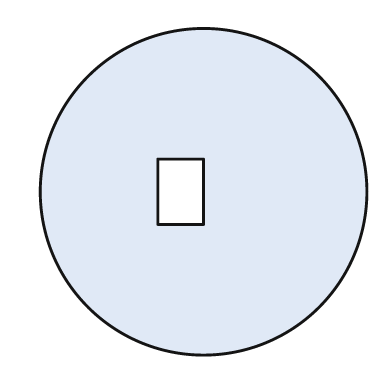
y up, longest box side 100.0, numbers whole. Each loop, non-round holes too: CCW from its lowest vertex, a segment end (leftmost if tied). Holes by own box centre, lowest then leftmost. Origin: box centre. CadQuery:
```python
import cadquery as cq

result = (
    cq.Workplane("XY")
    .moveTo(0.0, 0.0)
    .circle(50.0)
    .moveTo(-14.0, -10.0)
    .lineTo(0.0, -10.0)
    .lineTo(0.0, 10.0)
    .lineTo(-14.0, 10.0)
    .close()
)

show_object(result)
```